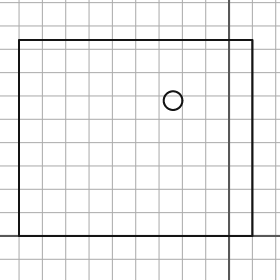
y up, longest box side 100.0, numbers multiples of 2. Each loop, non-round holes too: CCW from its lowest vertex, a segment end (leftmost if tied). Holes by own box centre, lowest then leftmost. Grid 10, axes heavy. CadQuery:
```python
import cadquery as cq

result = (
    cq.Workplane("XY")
    .moveTo(-90.0, 0.0)
    .lineTo(10.0, 0.0)
    .lineTo(10.0, 84.0)
    .lineTo(-90.0, 84.0)
    .close()
    .moveTo(-24.0, 58.0)
    .circle(4.0)
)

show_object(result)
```